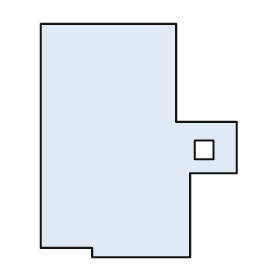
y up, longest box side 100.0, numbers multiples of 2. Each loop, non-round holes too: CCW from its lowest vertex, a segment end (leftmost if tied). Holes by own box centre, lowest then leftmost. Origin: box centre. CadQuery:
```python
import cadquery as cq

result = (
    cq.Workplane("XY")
    .moveTo(-20.0, -50.0)
    .lineTo(22.0, -50.0)
    .lineTo(22.0, -14.0)
    .lineTo(42.0, -14.0)
    .lineTo(42.0, 8.0)
    .lineTo(16.0, 8.0)
    .lineTo(16.0, 50.0)
    .lineTo(-42.0, 50.0)
    .lineTo(-42.0, -46.0)
    .lineTo(-20.0, -46.0)
    .close()
    .moveTo(24.0, -8.0)
    .lineTo(32.0, -8.0)
    .lineTo(32.0, 0.0)
    .lineTo(24.0, 0.0)
    .close()
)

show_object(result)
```